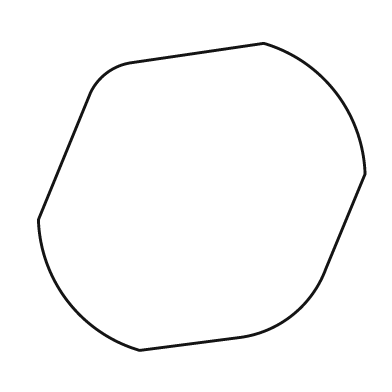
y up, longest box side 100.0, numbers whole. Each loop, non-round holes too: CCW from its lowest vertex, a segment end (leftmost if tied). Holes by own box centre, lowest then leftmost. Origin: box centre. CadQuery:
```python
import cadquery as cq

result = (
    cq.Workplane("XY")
    .moveTo(-19.0, -47.0)
    .lineTo(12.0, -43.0)
    .threePointArc((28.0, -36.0), (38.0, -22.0))
    .lineTo(50.0, 7.0)
    .threePointArc((41.0, 32.0), (19.0, 47.0))
    .lineTo(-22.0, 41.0)
    .threePointArc((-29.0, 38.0), (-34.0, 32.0))
    .lineTo(-50.0, -7.0)
    .threePointArc((-41.0, -32.0), (-19.0, -47.0))
    .close()
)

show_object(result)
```